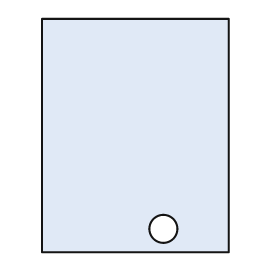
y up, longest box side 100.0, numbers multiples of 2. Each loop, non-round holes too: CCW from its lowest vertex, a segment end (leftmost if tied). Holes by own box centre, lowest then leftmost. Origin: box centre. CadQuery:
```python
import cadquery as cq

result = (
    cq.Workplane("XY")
    .moveTo(-40.0, -50.0)
    .lineTo(40.0, -50.0)
    .lineTo(40.0, 50.0)
    .lineTo(-40.0, 50.0)
    .close()
    .moveTo(12.0, -40.0)
    .circle(6.0)
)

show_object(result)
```